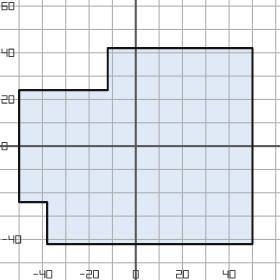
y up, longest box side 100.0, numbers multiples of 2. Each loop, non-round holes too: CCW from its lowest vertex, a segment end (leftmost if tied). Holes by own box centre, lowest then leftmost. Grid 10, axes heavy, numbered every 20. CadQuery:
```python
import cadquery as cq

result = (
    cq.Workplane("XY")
    .moveTo(-38.0, -42.0)
    .lineTo(50.0, -42.0)
    .lineTo(50.0, 42.0)
    .lineTo(-12.0, 42.0)
    .lineTo(-12.0, 24.0)
    .lineTo(-50.0, 24.0)
    .lineTo(-50.0, -24.0)
    .lineTo(-38.0, -24.0)
    .close()
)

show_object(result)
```